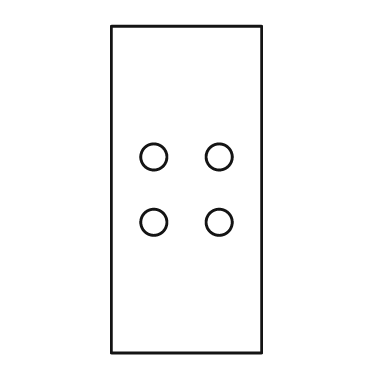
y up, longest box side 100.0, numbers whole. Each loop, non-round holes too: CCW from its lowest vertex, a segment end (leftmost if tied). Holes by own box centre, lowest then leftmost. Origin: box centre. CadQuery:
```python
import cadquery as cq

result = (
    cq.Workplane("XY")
    .moveTo(-23.0, -50.0)
    .lineTo(23.0, -50.0)
    .lineTo(23.0, 50.0)
    .lineTo(-23.0, 50.0)
    .close()
    .moveTo(-10.0, -10.0)
    .circle(4.0)
    .moveTo(10.0, -10.0)
    .circle(4.0)
    .moveTo(-10.0, 10.0)
    .circle(4.0)
    .moveTo(10.0, 10.0)
    .circle(4.0)
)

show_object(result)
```